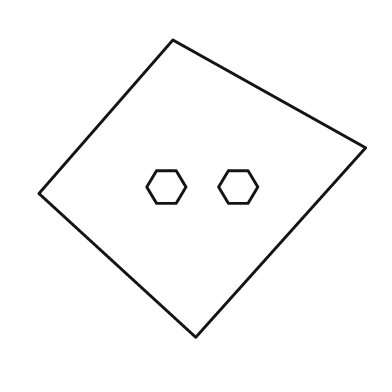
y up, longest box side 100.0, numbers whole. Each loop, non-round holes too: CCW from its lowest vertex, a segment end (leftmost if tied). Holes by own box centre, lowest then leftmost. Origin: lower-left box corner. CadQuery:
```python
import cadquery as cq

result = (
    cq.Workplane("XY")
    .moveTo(48.0, 0.0)
    .lineTo(100.0, 58.0)
    .lineTo(41.0, 91.0)
    .lineTo(0.0, 44.0)
    .close()
    .moveTo(36.0, 41.0)
    .lineTo(42.0, 41.0)
    .lineTo(45.0, 46.0)
    .lineTo(42.0, 51.0)
    .lineTo(36.0, 51.0)
    .lineTo(33.0, 46.0)
    .close()
    .moveTo(58.0, 41.0)
    .lineTo(64.0, 41.0)
    .lineTo(67.0, 46.0)
    .lineTo(64.0, 51.0)
    .lineTo(58.0, 51.0)
    .lineTo(55.0, 46.0)
    .close()
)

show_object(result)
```